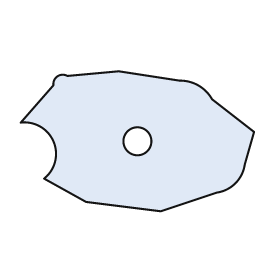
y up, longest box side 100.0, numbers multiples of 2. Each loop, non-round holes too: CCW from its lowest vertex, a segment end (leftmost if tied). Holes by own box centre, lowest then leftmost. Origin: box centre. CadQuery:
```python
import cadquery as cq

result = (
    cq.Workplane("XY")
    .moveTo(10.0, -30.0)
    .lineTo(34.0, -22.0)
    .threePointArc((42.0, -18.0), (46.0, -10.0))
    .lineTo(50.0, 4.0)
    .lineTo(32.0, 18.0)
    .threePointArc((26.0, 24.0), (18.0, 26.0))
    .lineTo(-8.0, 30.0)
    .lineTo(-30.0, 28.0)
    .threePointArc((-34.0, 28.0), (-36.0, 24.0))
    .lineTo(-50.0, 8.0)
    .threePointArc((-36.0, 0.0), (-40.0, -16.0))
    .lineTo(-22.0, -26.0)
    .close()
    .moveTo(0.0, 0.0)
    .circle(6.0)
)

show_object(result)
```